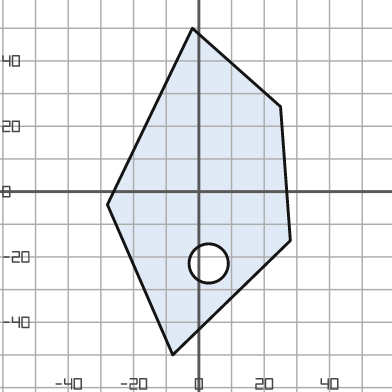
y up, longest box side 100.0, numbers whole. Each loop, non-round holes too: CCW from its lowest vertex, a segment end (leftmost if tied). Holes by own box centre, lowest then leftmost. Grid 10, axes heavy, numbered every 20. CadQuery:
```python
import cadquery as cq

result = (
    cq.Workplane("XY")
    .moveTo(-8.0, -50.0)
    .lineTo(28.0, -15.0)
    .lineTo(25.0, 26.0)
    .lineTo(-2.0, 50.0)
    .lineTo(-28.0, -4.0)
    .close()
    .moveTo(3.0, -22.0)
    .circle(6.0)
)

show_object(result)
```